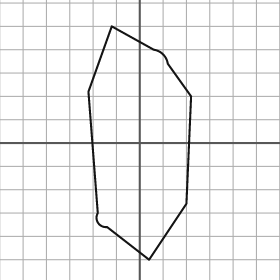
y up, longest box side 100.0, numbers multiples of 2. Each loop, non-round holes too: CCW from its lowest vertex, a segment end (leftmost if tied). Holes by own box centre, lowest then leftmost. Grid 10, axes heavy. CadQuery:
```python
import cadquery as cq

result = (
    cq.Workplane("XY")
    .moveTo(4.0, -50.0)
    .lineTo(20.0, -26.0)
    .lineTo(22.0, 20.0)
    .lineTo(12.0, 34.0)
    .threePointArc((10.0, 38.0), (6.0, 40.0))
    .lineTo(-12.0, 50.0)
    .lineTo(-22.0, 22.0)
    .lineTo(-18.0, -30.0)
    .threePointArc((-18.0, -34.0), (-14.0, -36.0))
    .close()
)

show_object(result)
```